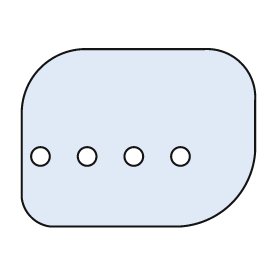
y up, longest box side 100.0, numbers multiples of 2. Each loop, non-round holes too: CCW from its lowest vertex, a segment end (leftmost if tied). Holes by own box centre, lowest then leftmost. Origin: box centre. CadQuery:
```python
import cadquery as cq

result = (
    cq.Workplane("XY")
    .moveTo(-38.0, -38.0)
    .lineTo(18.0, -38.0)
    .threePointArc((40.0, -28.0), (50.0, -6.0))
    .lineTo(50.0, 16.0)
    .threePointArc((44.0, 32.0), (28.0, 38.0))
    .lineTo(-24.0, 38.0)
    .threePointArc((-42.0, 30.0), (-50.0, 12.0))
    .lineTo(-50.0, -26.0)
    .threePointArc((-46.0, -34.0), (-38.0, -38.0))
    .close()
    .moveTo(-42.0, -8.0)
    .circle(4.0)
    .moveTo(-22.0, -8.0)
    .circle(4.0)
    .moveTo(-2.0, -8.0)
    .circle(4.0)
    .moveTo(18.0, -8.0)
    .circle(4.0)
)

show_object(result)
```